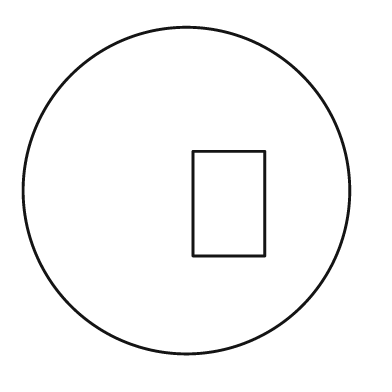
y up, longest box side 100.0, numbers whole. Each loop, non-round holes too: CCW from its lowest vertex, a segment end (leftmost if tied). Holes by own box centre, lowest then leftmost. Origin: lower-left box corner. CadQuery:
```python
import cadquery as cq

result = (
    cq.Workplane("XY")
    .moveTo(50.0, 50.0)
    .circle(50.0)
    .moveTo(52.0, 30.0)
    .lineTo(74.0, 30.0)
    .lineTo(74.0, 62.0)
    .lineTo(52.0, 62.0)
    .close()
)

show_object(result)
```